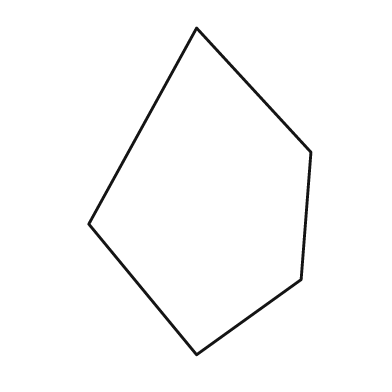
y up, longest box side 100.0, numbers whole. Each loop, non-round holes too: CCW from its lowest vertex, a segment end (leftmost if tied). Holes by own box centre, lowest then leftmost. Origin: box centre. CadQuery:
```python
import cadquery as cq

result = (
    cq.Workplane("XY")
    .moveTo(-1.0, -50.0)
    .lineTo(31.0, -27.0)
    .lineTo(34.0, 12.0)
    .lineTo(-1.0, 50.0)
    .lineTo(-34.0, -10.0)
    .close()
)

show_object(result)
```